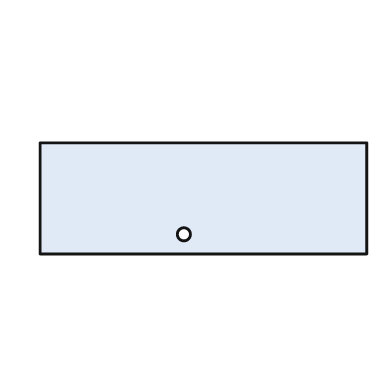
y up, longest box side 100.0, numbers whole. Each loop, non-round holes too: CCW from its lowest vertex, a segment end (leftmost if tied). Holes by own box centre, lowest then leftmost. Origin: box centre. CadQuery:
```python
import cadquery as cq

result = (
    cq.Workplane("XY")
    .moveTo(-50.0, -17.0)
    .lineTo(50.0, -17.0)
    .lineTo(50.0, 17.0)
    .lineTo(-50.0, 17.0)
    .close()
    .moveTo(-6.0, -11.0)
    .circle(2.0)
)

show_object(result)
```